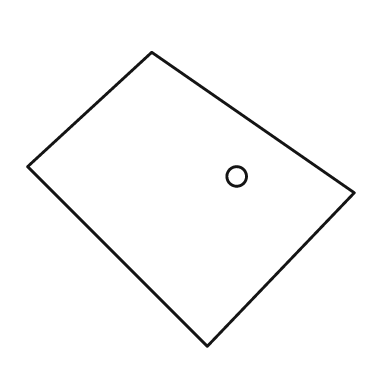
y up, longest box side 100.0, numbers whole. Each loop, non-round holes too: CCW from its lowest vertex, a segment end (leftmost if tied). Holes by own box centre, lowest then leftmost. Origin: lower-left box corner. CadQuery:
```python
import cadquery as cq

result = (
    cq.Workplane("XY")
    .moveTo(55.0, 0.0)
    .lineTo(100.0, 47.0)
    .lineTo(38.0, 90.0)
    .lineTo(0.0, 55.0)
    .close()
    .moveTo(64.0, 52.0)
    .circle(3.0)
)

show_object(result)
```